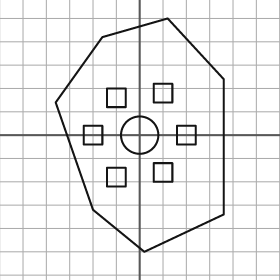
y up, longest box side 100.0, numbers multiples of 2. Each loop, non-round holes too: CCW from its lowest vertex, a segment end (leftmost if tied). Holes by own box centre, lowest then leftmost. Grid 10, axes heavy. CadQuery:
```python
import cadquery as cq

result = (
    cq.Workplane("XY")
    .moveTo(2.0, -50.0)
    .lineTo(36.0, -34.0)
    .lineTo(36.0, 24.0)
    .lineTo(12.0, 50.0)
    .lineTo(-16.0, 42.0)
    .lineTo(-36.0, 14.0)
    .lineTo(-20.0, -32.0)
    .close()
    .moveTo(-14.0, -22.0)
    .lineTo(-6.0, -22.0)
    .lineTo(-6.0, -14.0)
    .lineTo(-14.0, -14.0)
    .close()
    .moveTo(6.0, -20.0)
    .lineTo(14.0, -20.0)
    .lineTo(14.0, -12.0)
    .lineTo(6.0, -12.0)
    .close()
    .moveTo(-24.0, -4.0)
    .lineTo(-16.0, -4.0)
    .lineTo(-16.0, 4.0)
    .lineTo(-24.0, 4.0)
    .close()
    .moveTo(0.0, 0.0)
    .circle(8.0)
    .moveTo(16.0, -4.0)
    .lineTo(24.0, -4.0)
    .lineTo(24.0, 4.0)
    .lineTo(16.0, 4.0)
    .close()
    .moveTo(-14.0, 12.0)
    .lineTo(-6.0, 12.0)
    .lineTo(-6.0, 20.0)
    .lineTo(-14.0, 20.0)
    .close()
    .moveTo(6.0, 14.0)
    .lineTo(14.0, 14.0)
    .lineTo(14.0, 22.0)
    .lineTo(6.0, 22.0)
    .close()
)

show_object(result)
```